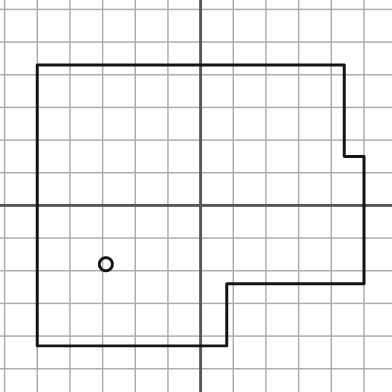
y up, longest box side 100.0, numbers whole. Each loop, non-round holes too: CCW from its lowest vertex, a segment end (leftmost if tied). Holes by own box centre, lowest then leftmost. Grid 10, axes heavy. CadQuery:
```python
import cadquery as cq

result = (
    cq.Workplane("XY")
    .moveTo(-50.0, -43.0)
    .lineTo(8.0, -43.0)
    .lineTo(8.0, -24.0)
    .lineTo(50.0, -24.0)
    .lineTo(50.0, 15.0)
    .lineTo(44.0, 15.0)
    .lineTo(44.0, 43.0)
    .lineTo(-50.0, 43.0)
    .close()
    .moveTo(-29.0, -18.0)
    .circle(2.0)
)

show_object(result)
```